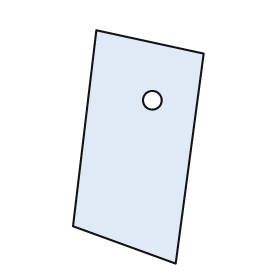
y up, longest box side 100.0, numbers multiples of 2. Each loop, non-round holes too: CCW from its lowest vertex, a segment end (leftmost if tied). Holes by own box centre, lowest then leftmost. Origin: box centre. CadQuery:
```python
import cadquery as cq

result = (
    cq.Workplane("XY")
    .moveTo(16.0, -50.0)
    .lineTo(28.0, 40.0)
    .lineTo(-18.0, 50.0)
    .lineTo(-28.0, -34.0)
    .close()
    .moveTo(6.0, 20.0)
    .circle(4.0)
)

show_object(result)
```